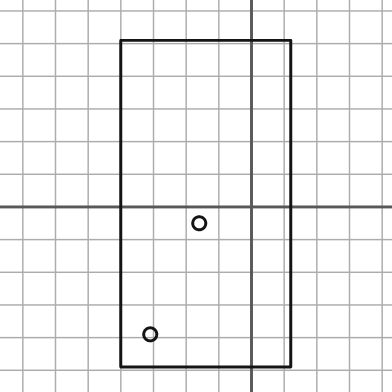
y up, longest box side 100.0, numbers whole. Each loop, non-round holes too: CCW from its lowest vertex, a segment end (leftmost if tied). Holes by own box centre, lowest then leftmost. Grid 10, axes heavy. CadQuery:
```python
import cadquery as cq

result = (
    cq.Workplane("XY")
    .moveTo(-40.0, -49.0)
    .lineTo(12.0, -49.0)
    .lineTo(12.0, 51.0)
    .lineTo(-40.0, 51.0)
    .close()
    .moveTo(-31.0, -39.0)
    .circle(2.0)
    .moveTo(-16.0, -5.0)
    .circle(2.0)
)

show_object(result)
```